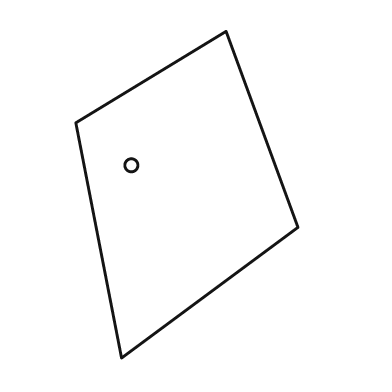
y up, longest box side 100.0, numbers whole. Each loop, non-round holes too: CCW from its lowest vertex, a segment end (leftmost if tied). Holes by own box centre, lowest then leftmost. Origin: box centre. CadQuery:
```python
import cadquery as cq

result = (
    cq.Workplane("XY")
    .moveTo(-20.0, -50.0)
    .lineTo(34.0, -10.0)
    .lineTo(12.0, 50.0)
    .lineTo(-34.0, 22.0)
    .close()
    .moveTo(-17.0, 9.0)
    .circle(2.0)
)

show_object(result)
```